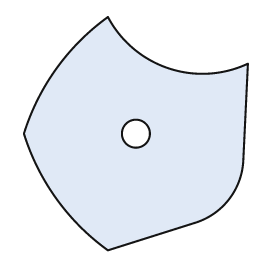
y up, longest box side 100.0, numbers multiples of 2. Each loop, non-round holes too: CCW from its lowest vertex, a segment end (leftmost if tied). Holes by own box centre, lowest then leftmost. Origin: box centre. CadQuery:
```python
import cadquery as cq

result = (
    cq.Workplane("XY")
    .moveTo(-12.0, -50.0)
    .lineTo(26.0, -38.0)
    .threePointArc((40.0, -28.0), (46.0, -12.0))
    .lineTo(48.0, 30.0)
    .threePointArc((14.0, 28.0), (-12.0, 50.0))
    .threePointArc((-34.0, 28.0), (-48.0, 0.0))
    .threePointArc((-34.0, -28.0), (-12.0, -50.0))
    .close()
    .moveTo(0.0, 0.0)
    .circle(6.0)
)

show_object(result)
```